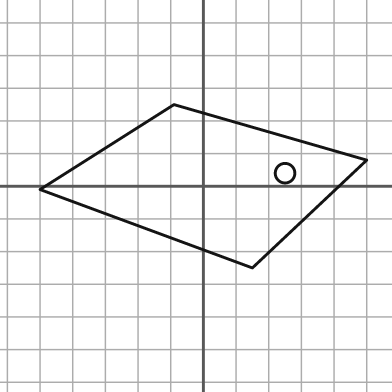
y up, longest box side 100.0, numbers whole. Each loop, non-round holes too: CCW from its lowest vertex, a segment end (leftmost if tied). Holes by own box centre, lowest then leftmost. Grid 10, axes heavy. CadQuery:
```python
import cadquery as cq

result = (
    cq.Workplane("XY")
    .moveTo(15.0, -25.0)
    .lineTo(50.0, 8.0)
    .lineTo(-9.0, 25.0)
    .lineTo(-50.0, -1.0)
    .close()
    .moveTo(25.0, 4.0)
    .circle(3.0)
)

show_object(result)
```